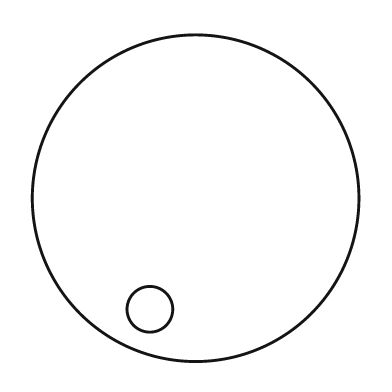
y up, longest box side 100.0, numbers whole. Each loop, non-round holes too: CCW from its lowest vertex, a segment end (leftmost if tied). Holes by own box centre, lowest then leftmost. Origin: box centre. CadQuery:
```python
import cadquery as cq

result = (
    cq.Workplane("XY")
    .moveTo(0.0, 0.0)
    .circle(50.0)
    .moveTo(-14.0, -34.0)
    .circle(7.0)
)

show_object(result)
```